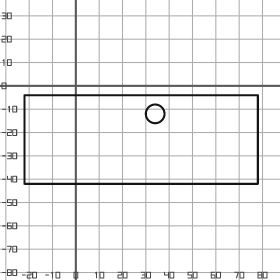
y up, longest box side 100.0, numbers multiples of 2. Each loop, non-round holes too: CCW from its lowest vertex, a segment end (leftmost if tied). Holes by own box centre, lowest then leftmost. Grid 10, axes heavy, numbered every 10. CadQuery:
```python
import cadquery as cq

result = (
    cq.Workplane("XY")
    .moveTo(-22.0, -42.0)
    .lineTo(78.0, -42.0)
    .lineTo(78.0, -4.0)
    .lineTo(-22.0, -4.0)
    .close()
    .moveTo(34.0, -12.0)
    .circle(4.0)
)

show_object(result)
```